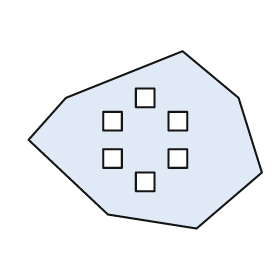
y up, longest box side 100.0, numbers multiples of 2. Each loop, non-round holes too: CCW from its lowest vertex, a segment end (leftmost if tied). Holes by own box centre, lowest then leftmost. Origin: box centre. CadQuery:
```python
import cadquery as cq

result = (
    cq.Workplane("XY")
    .moveTo(22.0, -38.0)
    .lineTo(50.0, -14.0)
    .lineTo(40.0, 18.0)
    .lineTo(16.0, 38.0)
    .lineTo(-34.0, 18.0)
    .lineTo(-50.0, 0.0)
    .lineTo(-16.0, -32.0)
    .close()
    .moveTo(-4.0, -22.0)
    .lineTo(4.0, -22.0)
    .lineTo(4.0, -14.0)
    .lineTo(-4.0, -14.0)
    .close()
    .moveTo(-18.0, -12.0)
    .lineTo(-10.0, -12.0)
    .lineTo(-10.0, -4.0)
    .lineTo(-18.0, -4.0)
    .close()
    .moveTo(10.0, -12.0)
    .lineTo(18.0, -12.0)
    .lineTo(18.0, -4.0)
    .lineTo(10.0, -4.0)
    .close()
    .moveTo(-18.0, 4.0)
    .lineTo(-10.0, 4.0)
    .lineTo(-10.0, 12.0)
    .lineTo(-18.0, 12.0)
    .close()
    .moveTo(10.0, 4.0)
    .lineTo(18.0, 4.0)
    .lineTo(18.0, 12.0)
    .lineTo(10.0, 12.0)
    .close()
    .moveTo(-4.0, 14.0)
    .lineTo(4.0, 14.0)
    .lineTo(4.0, 22.0)
    .lineTo(-4.0, 22.0)
    .close()
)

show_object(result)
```